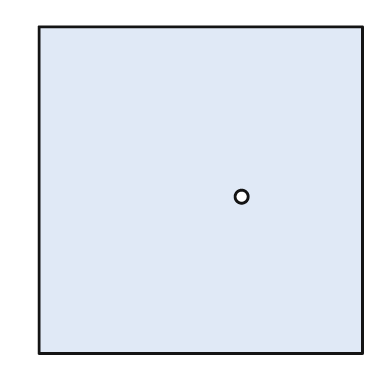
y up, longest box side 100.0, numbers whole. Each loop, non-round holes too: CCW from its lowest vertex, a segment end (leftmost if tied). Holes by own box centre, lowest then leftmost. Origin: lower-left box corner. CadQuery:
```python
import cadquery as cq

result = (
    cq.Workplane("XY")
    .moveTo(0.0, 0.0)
    .lineTo(99.0, 0.0)
    .lineTo(99.0, 100.0)
    .lineTo(0.0, 100.0)
    .close()
    .moveTo(62.0, 48.0)
    .circle(2.0)
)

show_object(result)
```